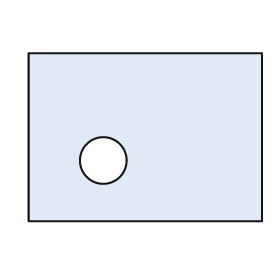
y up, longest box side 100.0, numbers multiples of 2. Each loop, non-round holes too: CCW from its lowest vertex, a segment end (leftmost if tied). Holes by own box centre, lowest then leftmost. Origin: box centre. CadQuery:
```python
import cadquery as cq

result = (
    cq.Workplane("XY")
    .moveTo(-50.0, -36.0)
    .lineTo(50.0, -36.0)
    .lineTo(50.0, 36.0)
    .lineTo(-50.0, 36.0)
    .close()
    .moveTo(-18.0, -10.0)
    .circle(10.0)
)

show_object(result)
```